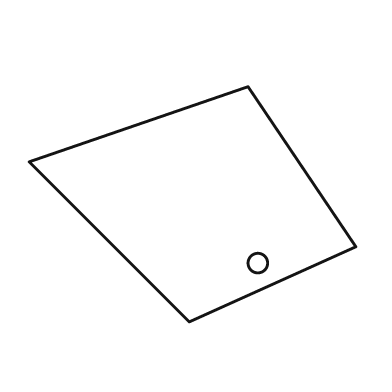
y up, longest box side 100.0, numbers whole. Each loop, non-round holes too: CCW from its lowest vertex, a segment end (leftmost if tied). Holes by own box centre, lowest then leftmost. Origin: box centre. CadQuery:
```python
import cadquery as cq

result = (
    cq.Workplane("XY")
    .moveTo(-1.0, -36.0)
    .lineTo(50.0, -13.0)
    .lineTo(17.0, 36.0)
    .lineTo(-50.0, 13.0)
    .close()
    .moveTo(20.0, -18.0)
    .circle(3.0)
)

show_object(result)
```